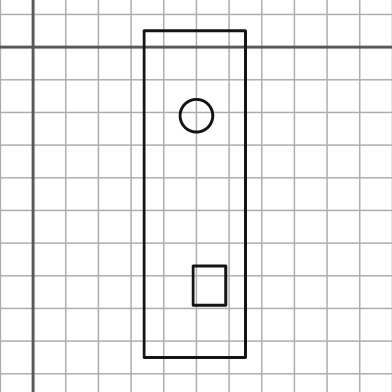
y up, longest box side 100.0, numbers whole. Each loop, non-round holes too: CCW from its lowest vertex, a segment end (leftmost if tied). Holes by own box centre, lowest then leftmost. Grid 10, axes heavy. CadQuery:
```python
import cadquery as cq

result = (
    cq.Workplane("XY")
    .moveTo(34.0, -95.0)
    .lineTo(65.0, -95.0)
    .lineTo(65.0, 5.0)
    .lineTo(34.0, 5.0)
    .close()
    .moveTo(49.0, -79.0)
    .lineTo(59.0, -79.0)
    .lineTo(59.0, -67.0)
    .lineTo(49.0, -67.0)
    .close()
    .moveTo(50.0, -21.0)
    .circle(5.0)
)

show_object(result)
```